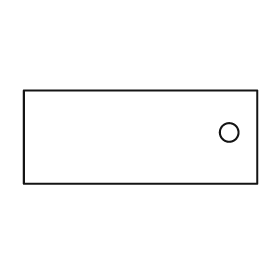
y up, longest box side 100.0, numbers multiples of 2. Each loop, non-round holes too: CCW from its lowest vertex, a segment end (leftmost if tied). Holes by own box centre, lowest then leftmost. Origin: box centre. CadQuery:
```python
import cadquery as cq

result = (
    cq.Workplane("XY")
    .moveTo(-50.0, -20.0)
    .lineTo(50.0, -20.0)
    .lineTo(50.0, 20.0)
    .lineTo(-50.0, 20.0)
    .close()
    .moveTo(38.0, 2.0)
    .circle(4.0)
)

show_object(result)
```